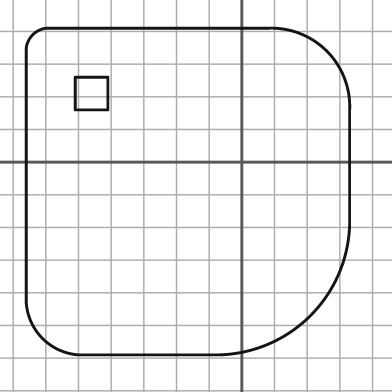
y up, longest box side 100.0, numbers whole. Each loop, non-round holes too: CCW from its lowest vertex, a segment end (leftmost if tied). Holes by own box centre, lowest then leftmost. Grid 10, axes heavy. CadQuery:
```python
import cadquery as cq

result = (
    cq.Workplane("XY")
    .moveTo(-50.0, -59.0)
    .lineTo(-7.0, -59.0)
    .threePointArc((21.0, -47.0), (33.0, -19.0))
    .lineTo(33.0, 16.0)
    .threePointArc((26.0, 34.0), (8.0, 41.0))
    .lineTo(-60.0, 41.0)
    .threePointArc((-64.0, 39.0), (-66.0, 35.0))
    .lineTo(-66.0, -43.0)
    .threePointArc((-61.0, -54.0), (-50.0, -59.0))
    .close()
    .moveTo(-51.0, 16.0)
    .lineTo(-41.0, 16.0)
    .lineTo(-41.0, 26.0)
    .lineTo(-51.0, 26.0)
    .close()
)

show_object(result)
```